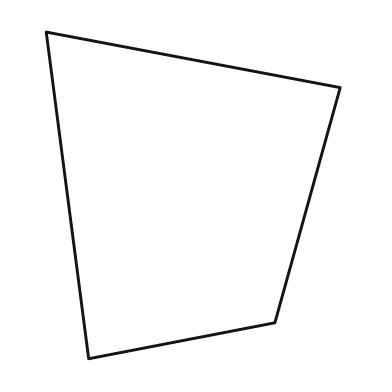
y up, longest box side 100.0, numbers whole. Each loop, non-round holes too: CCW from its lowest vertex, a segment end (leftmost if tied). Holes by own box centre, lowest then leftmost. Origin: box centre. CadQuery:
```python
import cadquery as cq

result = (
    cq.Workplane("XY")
    .moveTo(-32.0, -50.0)
    .lineTo(25.0, -39.0)
    .lineTo(45.0, 33.0)
    .lineTo(-45.0, 50.0)
    .close()
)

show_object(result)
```